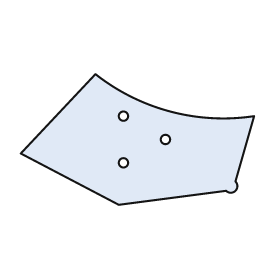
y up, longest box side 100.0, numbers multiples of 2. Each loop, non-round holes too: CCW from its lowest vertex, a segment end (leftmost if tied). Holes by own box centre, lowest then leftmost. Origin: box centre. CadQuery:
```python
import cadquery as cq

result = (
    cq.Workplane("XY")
    .moveTo(-8.0, -28.0)
    .lineTo(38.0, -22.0)
    .threePointArc((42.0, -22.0), (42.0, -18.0))
    .lineTo(50.0, 10.0)
    .threePointArc((14.0, 12.0), (-18.0, 28.0))
    .lineTo(-50.0, -6.0)
    .close()
    .moveTo(-6.0, -10.0)
    .circle(2.0)
    .moveTo(12.0, 0.0)
    .circle(2.0)
    .moveTo(-6.0, 10.0)
    .circle(2.0)
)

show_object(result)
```